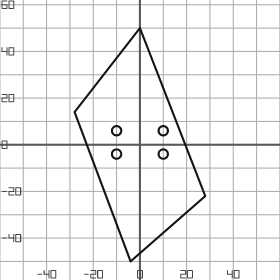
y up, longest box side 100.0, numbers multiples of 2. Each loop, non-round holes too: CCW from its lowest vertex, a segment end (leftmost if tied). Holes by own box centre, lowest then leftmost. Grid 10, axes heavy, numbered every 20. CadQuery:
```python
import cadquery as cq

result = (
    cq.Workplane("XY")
    .moveTo(-4.0, -50.0)
    .lineTo(28.0, -22.0)
    .lineTo(0.0, 50.0)
    .lineTo(-28.0, 14.0)
    .close()
    .moveTo(-10.0, -4.0)
    .circle(2.0)
    .moveTo(10.0, -4.0)
    .circle(2.0)
    .moveTo(-10.0, 6.0)
    .circle(2.0)
    .moveTo(10.0, 6.0)
    .circle(2.0)
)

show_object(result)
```